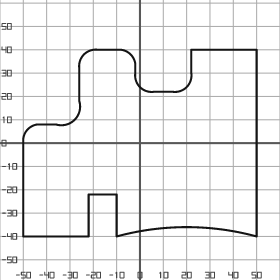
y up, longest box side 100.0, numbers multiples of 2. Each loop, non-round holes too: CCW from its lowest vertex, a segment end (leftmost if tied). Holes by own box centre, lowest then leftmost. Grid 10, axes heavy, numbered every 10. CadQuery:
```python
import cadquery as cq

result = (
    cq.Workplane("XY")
    .moveTo(-50.0, -40.0)
    .lineTo(-22.0, -40.0)
    .lineTo(-22.0, -22.0)
    .lineTo(-10.0, -22.0)
    .lineTo(-10.0, -40.0)
    .threePointArc((20.0, -36.0), (50.0, -40.0))
    .lineTo(50.0, 40.0)
    .lineTo(22.0, 40.0)
    .lineTo(22.0, 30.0)
    .threePointArc((20.0, 24.0), (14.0, 22.0))
    .lineTo(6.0, 22.0)
    .threePointArc((0.0, 24.0), (-2.0, 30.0))
    .lineTo(-2.0, 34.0)
    .threePointArc((-4.0, 38.0), (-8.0, 40.0))
    .lineTo(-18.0, 40.0)
    .threePointArc((-24.0, 38.0), (-26.0, 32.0))
    .lineTo(-26.0, 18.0)
    .threePointArc((-28.0, 10.0), (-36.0, 8.0))
    .lineTo(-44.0, 8.0)
    .threePointArc((-48.0, 6.0), (-50.0, 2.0))
    .close()
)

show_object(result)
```